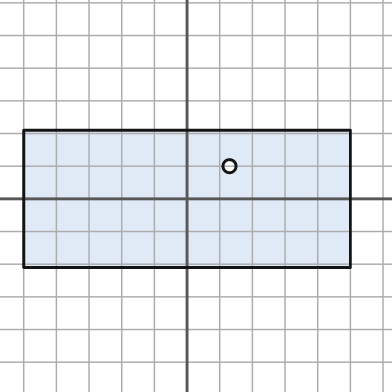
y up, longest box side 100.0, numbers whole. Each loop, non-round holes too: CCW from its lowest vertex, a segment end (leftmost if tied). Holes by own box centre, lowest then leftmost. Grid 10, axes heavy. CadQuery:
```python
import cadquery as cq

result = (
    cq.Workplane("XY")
    .moveTo(-50.0, -21.0)
    .lineTo(50.0, -21.0)
    .lineTo(50.0, 21.0)
    .lineTo(-50.0, 21.0)
    .close()
    .moveTo(13.0, 10.0)
    .circle(2.0)
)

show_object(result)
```